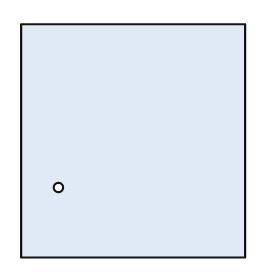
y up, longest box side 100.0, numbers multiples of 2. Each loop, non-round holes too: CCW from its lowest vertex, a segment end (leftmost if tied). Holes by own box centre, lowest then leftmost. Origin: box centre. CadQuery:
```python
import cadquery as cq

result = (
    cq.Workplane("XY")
    .moveTo(-48.0, -50.0)
    .lineTo(48.0, -50.0)
    .lineTo(48.0, 50.0)
    .lineTo(-48.0, 50.0)
    .close()
    .moveTo(-32.0, -20.0)
    .circle(2.0)
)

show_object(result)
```